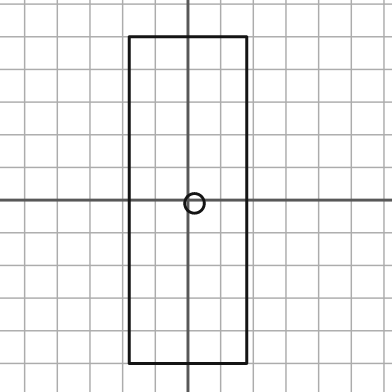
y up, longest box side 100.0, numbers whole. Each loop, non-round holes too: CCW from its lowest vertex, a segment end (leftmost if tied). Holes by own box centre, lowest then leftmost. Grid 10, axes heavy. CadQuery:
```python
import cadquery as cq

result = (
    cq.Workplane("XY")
    .moveTo(-18.0, -50.0)
    .lineTo(18.0, -50.0)
    .lineTo(18.0, 50.0)
    .lineTo(-18.0, 50.0)
    .close()
    .moveTo(2.0, -1.0)
    .circle(3.0)
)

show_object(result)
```